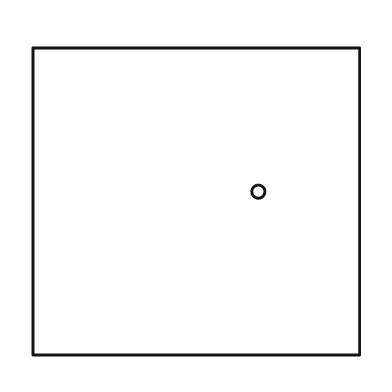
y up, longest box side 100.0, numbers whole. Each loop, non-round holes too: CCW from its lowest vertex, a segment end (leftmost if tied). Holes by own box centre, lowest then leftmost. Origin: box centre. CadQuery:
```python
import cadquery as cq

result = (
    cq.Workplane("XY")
    .moveTo(-50.0, -47.0)
    .lineTo(50.0, -47.0)
    .lineTo(50.0, 47.0)
    .lineTo(-50.0, 47.0)
    .close()
    .moveTo(19.0, 3.0)
    .circle(2.0)
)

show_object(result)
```